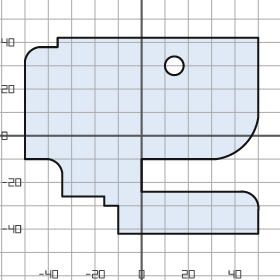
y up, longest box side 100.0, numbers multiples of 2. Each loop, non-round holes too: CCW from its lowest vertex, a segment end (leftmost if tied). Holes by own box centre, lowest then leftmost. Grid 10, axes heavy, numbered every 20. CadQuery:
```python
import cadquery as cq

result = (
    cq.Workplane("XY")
    .moveTo(-10.0, -42.0)
    .lineTo(50.0, -42.0)
    .lineTo(50.0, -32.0)
    .threePointArc((48.0, -26.0), (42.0, -24.0))
    .lineTo(0.0, -24.0)
    .lineTo(0.0, -10.0)
    .lineTo(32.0, -10.0)
    .threePointArc((44.0, -4.0), (50.0, 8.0))
    .lineTo(50.0, 42.0)
    .lineTo(-36.0, 42.0)
    .lineTo(-36.0, 38.0)
    .lineTo(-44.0, 38.0)
    .threePointArc((-48.0, 36.0), (-50.0, 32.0))
    .lineTo(-50.0, -10.0)
    .lineTo(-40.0, -10.0)
    .threePointArc((-36.0, -12.0), (-34.0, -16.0))
    .lineTo(-34.0, -26.0)
    .lineTo(-16.0, -26.0)
    .lineTo(-16.0, -30.0)
    .lineTo(-10.0, -30.0)
    .close()
    .moveTo(14.0, 30.0)
    .circle(4.0)
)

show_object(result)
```